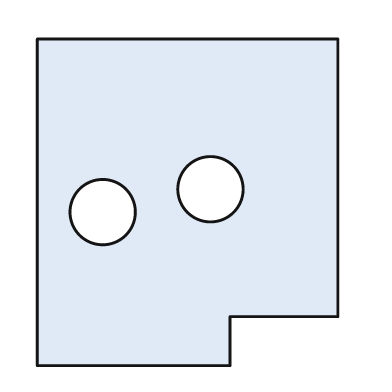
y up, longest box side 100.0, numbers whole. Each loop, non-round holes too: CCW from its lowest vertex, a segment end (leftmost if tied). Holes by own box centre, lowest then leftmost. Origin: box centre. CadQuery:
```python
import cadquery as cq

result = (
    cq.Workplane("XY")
    .moveTo(-46.0, -50.0)
    .lineTo(13.0, -50.0)
    .lineTo(13.0, -35.0)
    .lineTo(46.0, -35.0)
    .lineTo(46.0, 50.0)
    .lineTo(-46.0, 50.0)
    .close()
    .moveTo(-26.0, -3.0)
    .circle(10.0)
    .moveTo(7.0, 4.0)
    .circle(10.0)
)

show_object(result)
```